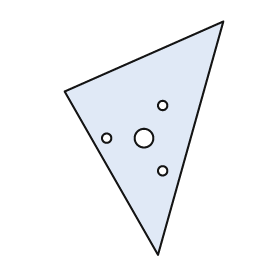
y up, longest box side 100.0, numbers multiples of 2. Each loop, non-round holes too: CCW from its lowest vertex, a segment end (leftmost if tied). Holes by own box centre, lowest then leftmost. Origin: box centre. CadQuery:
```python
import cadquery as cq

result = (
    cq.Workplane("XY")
    .moveTo(6.0, -50.0)
    .lineTo(34.0, 50.0)
    .lineTo(-34.0, 20.0)
    .close()
    .moveTo(8.0, -14.0)
    .circle(2.0)
    .moveTo(-16.0, 0.0)
    .circle(2.0)
    .moveTo(0.0, 0.0)
    .circle(4.0)
    .moveTo(8.0, 14.0)
    .circle(2.0)
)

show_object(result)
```